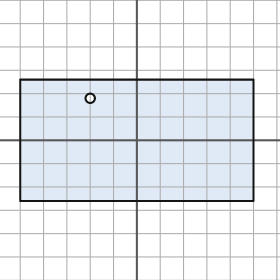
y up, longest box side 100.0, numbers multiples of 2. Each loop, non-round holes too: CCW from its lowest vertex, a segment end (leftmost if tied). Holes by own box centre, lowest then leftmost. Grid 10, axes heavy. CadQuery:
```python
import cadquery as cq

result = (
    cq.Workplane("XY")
    .moveTo(-50.0, -26.0)
    .lineTo(50.0, -26.0)
    .lineTo(50.0, 26.0)
    .lineTo(-50.0, 26.0)
    .close()
    .moveTo(-20.0, 18.0)
    .circle(2.0)
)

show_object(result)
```